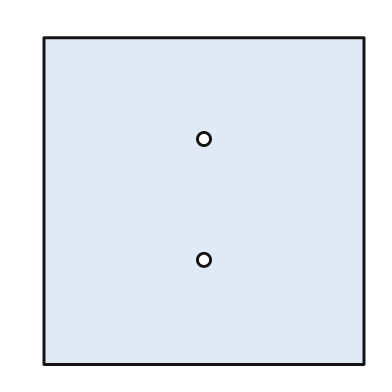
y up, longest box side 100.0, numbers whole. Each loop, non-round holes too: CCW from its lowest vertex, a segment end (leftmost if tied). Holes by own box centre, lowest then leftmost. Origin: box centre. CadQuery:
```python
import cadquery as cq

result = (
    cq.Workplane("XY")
    .moveTo(-49.0, -50.0)
    .lineTo(49.0, -50.0)
    .lineTo(49.0, 50.0)
    .lineTo(-49.0, 50.0)
    .close()
    .moveTo(0.0, -18.0)
    .circle(2.0)
    .moveTo(0.0, 19.0)
    .circle(2.0)
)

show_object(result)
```